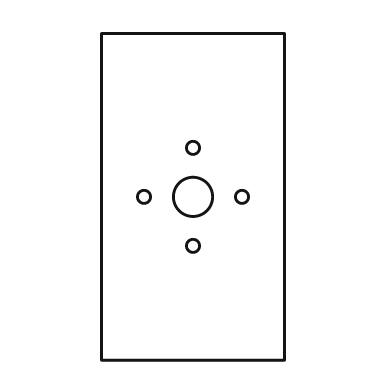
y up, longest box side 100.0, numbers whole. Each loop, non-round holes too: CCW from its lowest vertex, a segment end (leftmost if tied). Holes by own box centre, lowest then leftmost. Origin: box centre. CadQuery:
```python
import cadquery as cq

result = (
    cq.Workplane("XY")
    .moveTo(-28.0, -50.0)
    .lineTo(28.0, -50.0)
    .lineTo(28.0, 50.0)
    .lineTo(-28.0, 50.0)
    .close()
    .moveTo(0.0, -15.0)
    .circle(2.0)
    .moveTo(-15.0, 0.0)
    .circle(2.0)
    .moveTo(0.0, 0.0)
    .circle(6.0)
    .moveTo(15.0, 0.0)
    .circle(2.0)
    .moveTo(0.0, 15.0)
    .circle(2.0)
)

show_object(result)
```